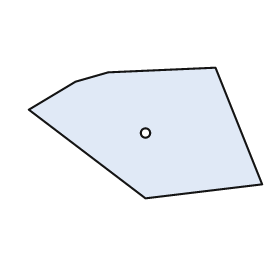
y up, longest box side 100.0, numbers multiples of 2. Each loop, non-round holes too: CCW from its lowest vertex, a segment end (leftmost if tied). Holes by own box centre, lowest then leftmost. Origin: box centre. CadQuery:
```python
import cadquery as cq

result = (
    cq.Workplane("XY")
    .moveTo(0.0, -28.0)
    .lineTo(50.0, -22.0)
    .lineTo(30.0, 28.0)
    .lineTo(-16.0, 26.0)
    .lineTo(-30.0, 22.0)
    .lineTo(-50.0, 10.0)
    .close()
    .moveTo(0.0, 0.0)
    .circle(2.0)
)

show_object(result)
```